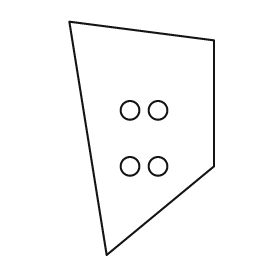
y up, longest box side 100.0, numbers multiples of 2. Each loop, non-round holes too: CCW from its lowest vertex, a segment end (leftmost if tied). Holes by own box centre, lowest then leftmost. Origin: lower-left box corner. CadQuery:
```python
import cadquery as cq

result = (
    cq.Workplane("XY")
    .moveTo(16.0, 0.0)
    .lineTo(62.0, 38.0)
    .lineTo(62.0, 92.0)
    .lineTo(0.0, 100.0)
    .close()
    .moveTo(26.0, 38.0)
    .circle(4.0)
    .moveTo(38.0, 38.0)
    .circle(4.0)
    .moveTo(26.0, 62.0)
    .circle(4.0)
    .moveTo(38.0, 62.0)
    .circle(4.0)
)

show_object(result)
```